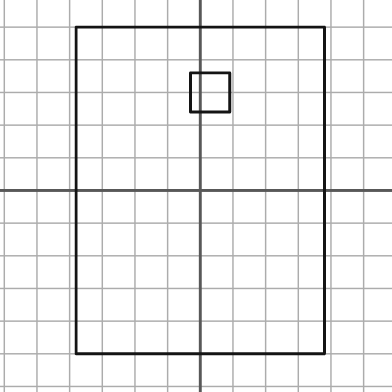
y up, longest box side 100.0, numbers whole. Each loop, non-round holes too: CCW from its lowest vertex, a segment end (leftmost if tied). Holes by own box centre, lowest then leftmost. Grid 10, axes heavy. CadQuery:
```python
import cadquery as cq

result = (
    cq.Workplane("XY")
    .moveTo(-38.0, -50.0)
    .lineTo(38.0, -50.0)
    .lineTo(38.0, 50.0)
    .lineTo(-38.0, 50.0)
    .close()
    .moveTo(-3.0, 24.0)
    .lineTo(9.0, 24.0)
    .lineTo(9.0, 36.0)
    .lineTo(-3.0, 36.0)
    .close()
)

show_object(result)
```